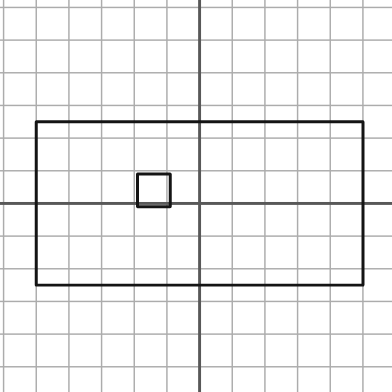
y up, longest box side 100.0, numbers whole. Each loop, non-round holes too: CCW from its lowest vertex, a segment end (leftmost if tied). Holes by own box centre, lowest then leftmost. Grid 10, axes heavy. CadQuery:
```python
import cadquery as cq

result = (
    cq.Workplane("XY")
    .moveTo(-50.0, -25.0)
    .lineTo(50.0, -25.0)
    .lineTo(50.0, 25.0)
    .lineTo(-50.0, 25.0)
    .close()
    .moveTo(-19.0, -1.0)
    .lineTo(-9.0, -1.0)
    .lineTo(-9.0, 9.0)
    .lineTo(-19.0, 9.0)
    .close()
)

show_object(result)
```